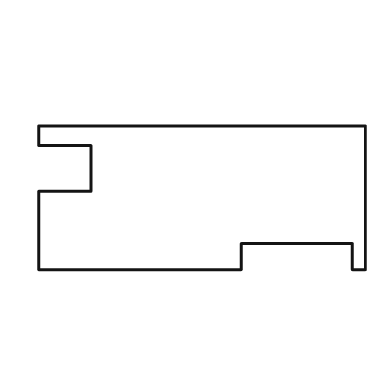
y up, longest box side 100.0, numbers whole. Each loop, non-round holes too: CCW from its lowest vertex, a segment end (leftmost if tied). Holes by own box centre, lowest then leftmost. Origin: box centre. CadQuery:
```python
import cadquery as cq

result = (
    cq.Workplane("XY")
    .moveTo(-50.0, -22.0)
    .lineTo(12.0, -22.0)
    .lineTo(12.0, -14.0)
    .lineTo(46.0, -14.0)
    .lineTo(46.0, -22.0)
    .lineTo(50.0, -22.0)
    .lineTo(50.0, 22.0)
    .lineTo(-50.0, 22.0)
    .lineTo(-50.0, 16.0)
    .lineTo(-34.0, 16.0)
    .lineTo(-34.0, 2.0)
    .lineTo(-50.0, 2.0)
    .close()
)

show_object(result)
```